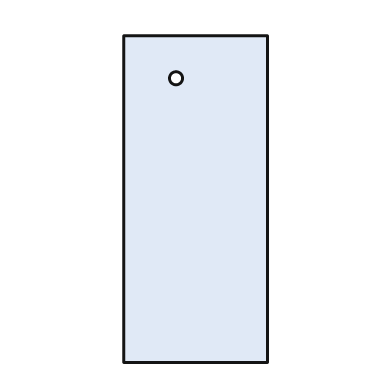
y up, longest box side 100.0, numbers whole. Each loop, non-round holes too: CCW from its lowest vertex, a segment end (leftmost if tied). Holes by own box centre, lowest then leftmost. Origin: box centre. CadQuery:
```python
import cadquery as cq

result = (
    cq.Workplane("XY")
    .moveTo(-22.0, -50.0)
    .lineTo(22.0, -50.0)
    .lineTo(22.0, 50.0)
    .lineTo(-22.0, 50.0)
    .close()
    .moveTo(-6.0, 37.0)
    .circle(2.0)
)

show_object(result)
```